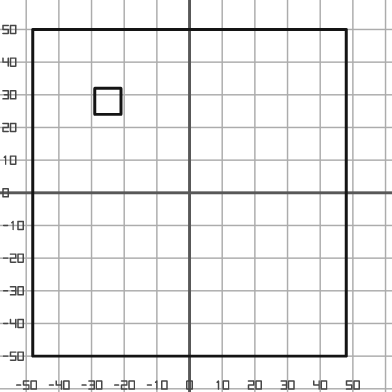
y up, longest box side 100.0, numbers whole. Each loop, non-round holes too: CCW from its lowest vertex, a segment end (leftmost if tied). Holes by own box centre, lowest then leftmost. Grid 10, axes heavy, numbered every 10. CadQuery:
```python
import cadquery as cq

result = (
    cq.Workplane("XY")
    .moveTo(-48.0, -50.0)
    .lineTo(48.0, -50.0)
    .lineTo(48.0, 50.0)
    .lineTo(-48.0, 50.0)
    .close()
    .moveTo(-29.0, 24.0)
    .lineTo(-21.0, 24.0)
    .lineTo(-21.0, 32.0)
    .lineTo(-29.0, 32.0)
    .close()
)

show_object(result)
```